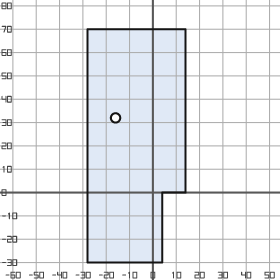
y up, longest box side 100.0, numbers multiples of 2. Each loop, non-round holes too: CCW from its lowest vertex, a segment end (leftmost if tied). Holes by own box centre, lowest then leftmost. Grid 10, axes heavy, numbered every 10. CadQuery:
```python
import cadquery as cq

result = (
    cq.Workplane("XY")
    .moveTo(-28.0, -30.0)
    .lineTo(4.0, -30.0)
    .lineTo(4.0, 0.0)
    .lineTo(14.0, 0.0)
    .lineTo(14.0, 70.0)
    .lineTo(-28.0, 70.0)
    .close()
    .moveTo(-16.0, 32.0)
    .circle(2.0)
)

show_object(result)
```